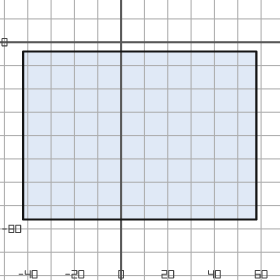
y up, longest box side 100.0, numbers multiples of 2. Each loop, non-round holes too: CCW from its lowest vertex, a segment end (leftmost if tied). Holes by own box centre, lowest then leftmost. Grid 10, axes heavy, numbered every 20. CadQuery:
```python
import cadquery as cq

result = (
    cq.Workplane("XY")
    .moveTo(-42.0, -76.0)
    .lineTo(58.0, -76.0)
    .lineTo(58.0, -4.0)
    .lineTo(-42.0, -4.0)
    .close()
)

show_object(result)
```